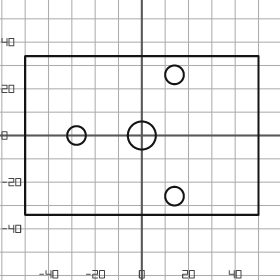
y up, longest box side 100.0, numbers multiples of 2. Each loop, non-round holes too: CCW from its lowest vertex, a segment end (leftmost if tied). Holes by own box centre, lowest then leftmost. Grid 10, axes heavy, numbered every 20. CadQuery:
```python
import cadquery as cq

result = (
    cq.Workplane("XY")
    .moveTo(-50.0, -34.0)
    .lineTo(50.0, -34.0)
    .lineTo(50.0, 34.0)
    .lineTo(-50.0, 34.0)
    .close()
    .moveTo(14.0, -26.0)
    .circle(4.0)
    .moveTo(-28.0, 0.0)
    .circle(4.0)
    .moveTo(0.0, 0.0)
    .circle(6.0)
    .moveTo(14.0, 26.0)
    .circle(4.0)
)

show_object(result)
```